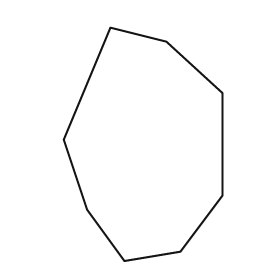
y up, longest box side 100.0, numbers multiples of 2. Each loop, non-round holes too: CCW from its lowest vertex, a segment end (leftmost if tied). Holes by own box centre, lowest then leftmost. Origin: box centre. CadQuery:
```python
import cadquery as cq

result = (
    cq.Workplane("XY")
    .moveTo(-8.0, -50.0)
    .lineTo(16.0, -46.0)
    .lineTo(34.0, -22.0)
    .lineTo(34.0, 22.0)
    .lineTo(10.0, 44.0)
    .lineTo(-14.0, 50.0)
    .lineTo(-34.0, 2.0)
    .lineTo(-24.0, -28.0)
    .close()
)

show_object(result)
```